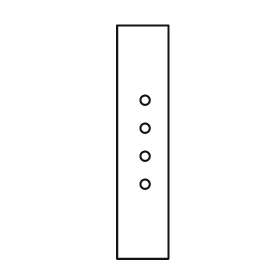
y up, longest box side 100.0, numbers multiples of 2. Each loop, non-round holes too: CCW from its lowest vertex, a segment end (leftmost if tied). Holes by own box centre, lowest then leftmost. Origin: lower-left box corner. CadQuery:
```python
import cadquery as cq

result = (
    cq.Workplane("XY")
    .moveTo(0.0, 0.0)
    .lineTo(22.0, 0.0)
    .lineTo(22.0, 100.0)
    .lineTo(0.0, 100.0)
    .close()
    .moveTo(12.0, 32.0)
    .circle(2.0)
    .moveTo(12.0, 44.0)
    .circle(2.0)
    .moveTo(12.0, 56.0)
    .circle(2.0)
    .moveTo(12.0, 68.0)
    .circle(2.0)
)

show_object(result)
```